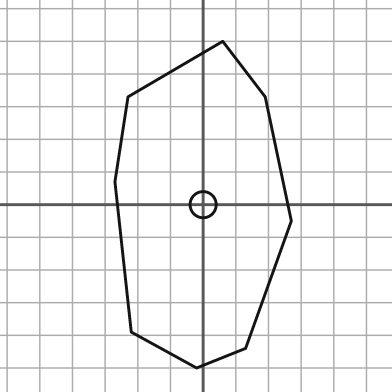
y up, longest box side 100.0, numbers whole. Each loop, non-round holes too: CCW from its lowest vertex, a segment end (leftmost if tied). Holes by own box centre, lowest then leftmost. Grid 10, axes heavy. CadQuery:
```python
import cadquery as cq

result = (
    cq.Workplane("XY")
    .moveTo(-2.0, -50.0)
    .lineTo(13.0, -44.0)
    .lineTo(27.0, -5.0)
    .lineTo(19.0, 33.0)
    .lineTo(6.0, 50.0)
    .lineTo(-23.0, 33.0)
    .lineTo(-27.0, 7.0)
    .lineTo(-22.0, -39.0)
    .close()
    .moveTo(0.0, 0.0)
    .circle(4.0)
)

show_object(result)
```